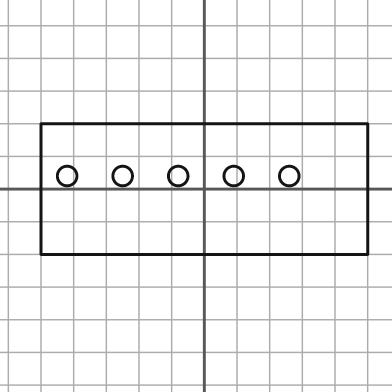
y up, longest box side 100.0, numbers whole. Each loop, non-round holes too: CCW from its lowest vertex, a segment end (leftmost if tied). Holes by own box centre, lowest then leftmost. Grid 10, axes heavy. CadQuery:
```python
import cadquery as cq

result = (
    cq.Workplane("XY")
    .moveTo(-50.0, -20.0)
    .lineTo(50.0, -20.0)
    .lineTo(50.0, 20.0)
    .lineTo(-50.0, 20.0)
    .close()
    .moveTo(-42.0, 4.0)
    .circle(3.0)
    .moveTo(-25.0, 4.0)
    .circle(3.0)
    .moveTo(-8.0, 4.0)
    .circle(3.0)
    .moveTo(9.0, 4.0)
    .circle(3.0)
    .moveTo(26.0, 4.0)
    .circle(3.0)
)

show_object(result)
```